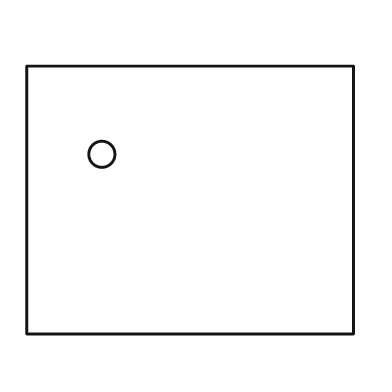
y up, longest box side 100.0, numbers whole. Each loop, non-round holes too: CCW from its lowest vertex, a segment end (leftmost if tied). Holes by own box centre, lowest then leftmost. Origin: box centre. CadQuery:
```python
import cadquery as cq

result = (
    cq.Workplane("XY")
    .moveTo(-50.0, -41.0)
    .lineTo(50.0, -41.0)
    .lineTo(50.0, 41.0)
    .lineTo(-50.0, 41.0)
    .close()
    .moveTo(-27.0, 14.0)
    .circle(4.0)
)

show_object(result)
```